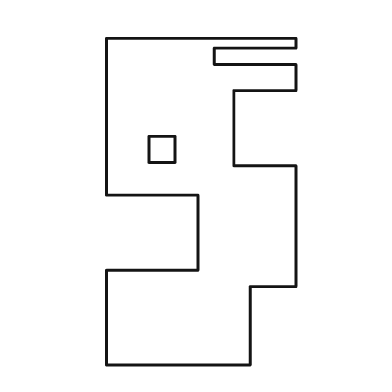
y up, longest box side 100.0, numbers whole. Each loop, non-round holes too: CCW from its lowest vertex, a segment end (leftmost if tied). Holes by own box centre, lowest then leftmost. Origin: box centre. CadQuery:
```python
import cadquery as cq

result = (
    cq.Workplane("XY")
    .moveTo(-29.0, -50.0)
    .lineTo(15.0, -50.0)
    .lineTo(15.0, -26.0)
    .lineTo(29.0, -26.0)
    .lineTo(29.0, 11.0)
    .lineTo(10.0, 11.0)
    .lineTo(10.0, 34.0)
    .lineTo(29.0, 34.0)
    .lineTo(29.0, 42.0)
    .lineTo(4.0, 42.0)
    .lineTo(4.0, 47.0)
    .lineTo(29.0, 47.0)
    .lineTo(29.0, 50.0)
    .lineTo(-29.0, 50.0)
    .lineTo(-29.0, 2.0)
    .lineTo(-1.0, 2.0)
    .lineTo(-1.0, -21.0)
    .lineTo(-29.0, -21.0)
    .close()
    .moveTo(-16.0, 12.0)
    .lineTo(-8.0, 12.0)
    .lineTo(-8.0, 20.0)
    .lineTo(-16.0, 20.0)
    .close()
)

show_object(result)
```